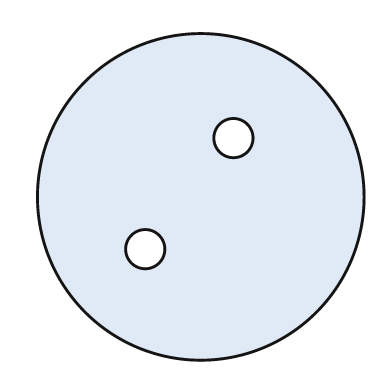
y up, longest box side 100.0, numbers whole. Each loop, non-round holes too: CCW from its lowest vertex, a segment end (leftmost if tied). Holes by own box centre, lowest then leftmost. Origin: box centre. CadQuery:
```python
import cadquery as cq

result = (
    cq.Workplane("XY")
    .moveTo(0.0, 0.0)
    .circle(50.0)
    .moveTo(-17.0, -16.0)
    .circle(6.0)
    .moveTo(10.0, 18.0)
    .circle(6.0)
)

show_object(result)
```